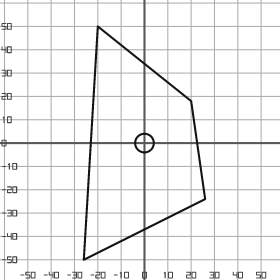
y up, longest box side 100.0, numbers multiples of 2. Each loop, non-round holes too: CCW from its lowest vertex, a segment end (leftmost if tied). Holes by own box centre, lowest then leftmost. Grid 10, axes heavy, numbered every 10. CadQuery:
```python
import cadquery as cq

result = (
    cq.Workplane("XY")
    .moveTo(-26.0, -50.0)
    .lineTo(26.0, -24.0)
    .lineTo(20.0, 18.0)
    .lineTo(-20.0, 50.0)
    .close()
    .moveTo(0.0, 0.0)
    .circle(4.0)
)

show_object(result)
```